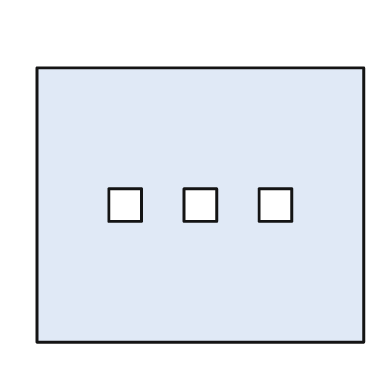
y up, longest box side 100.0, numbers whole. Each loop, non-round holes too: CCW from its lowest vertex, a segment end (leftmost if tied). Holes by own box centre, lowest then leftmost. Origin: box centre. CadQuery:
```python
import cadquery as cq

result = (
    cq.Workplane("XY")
    .moveTo(-50.0, -42.0)
    .lineTo(50.0, -42.0)
    .lineTo(50.0, 42.0)
    .lineTo(-50.0, 42.0)
    .close()
    .moveTo(-28.0, -5.0)
    .lineTo(-18.0, -5.0)
    .lineTo(-18.0, 5.0)
    .lineTo(-28.0, 5.0)
    .close()
    .moveTo(-5.0, -5.0)
    .lineTo(5.0, -5.0)
    .lineTo(5.0, 5.0)
    .lineTo(-5.0, 5.0)
    .close()
    .moveTo(18.0, -5.0)
    .lineTo(28.0, -5.0)
    .lineTo(28.0, 5.0)
    .lineTo(18.0, 5.0)
    .close()
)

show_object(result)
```